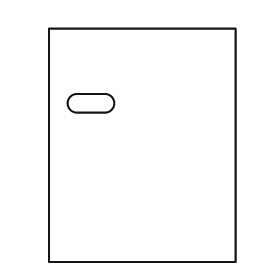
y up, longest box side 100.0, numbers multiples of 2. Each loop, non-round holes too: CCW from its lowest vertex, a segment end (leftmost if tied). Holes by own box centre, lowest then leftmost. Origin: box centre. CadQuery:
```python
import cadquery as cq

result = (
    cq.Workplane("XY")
    .moveTo(-40.0, -50.0)
    .lineTo(40.0, -50.0)
    .lineTo(40.0, 50.0)
    .lineTo(-40.0, 50.0)
    .close()
    .moveTo(-28.0, 14.0)
    .lineTo(-16.0, 14.0)
    .threePointArc((-12.0, 18.0), (-16.0, 22.0))
    .lineTo(-28.0, 22.0)
    .threePointArc((-32.0, 18.0), (-28.0, 14.0))
    .close()
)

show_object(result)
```